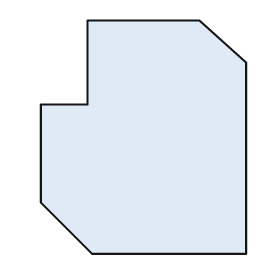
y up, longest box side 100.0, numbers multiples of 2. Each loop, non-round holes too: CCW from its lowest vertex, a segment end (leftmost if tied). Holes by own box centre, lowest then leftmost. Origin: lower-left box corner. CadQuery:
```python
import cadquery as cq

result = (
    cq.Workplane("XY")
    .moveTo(22.0, 0.0)
    .lineTo(88.0, 0.0)
    .lineTo(88.0, 82.0)
    .lineTo(68.0, 100.0)
    .lineTo(20.0, 100.0)
    .lineTo(20.0, 64.0)
    .lineTo(0.0, 64.0)
    .lineTo(0.0, 22.0)
    .close()
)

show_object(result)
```